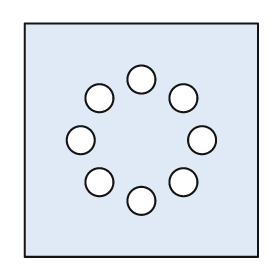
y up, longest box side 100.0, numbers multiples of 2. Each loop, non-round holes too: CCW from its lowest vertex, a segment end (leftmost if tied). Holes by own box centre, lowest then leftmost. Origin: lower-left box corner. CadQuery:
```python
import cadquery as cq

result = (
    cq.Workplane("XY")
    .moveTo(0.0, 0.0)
    .lineTo(100.0, 0.0)
    .lineTo(100.0, 100.0)
    .lineTo(0.0, 100.0)
    .close()
    .moveTo(50.0, 24.0)
    .circle(6.0)
    .moveTo(32.0, 32.0)
    .circle(6.0)
    .moveTo(68.0, 32.0)
    .circle(6.0)
    .moveTo(24.0, 50.0)
    .circle(6.0)
    .moveTo(76.0, 50.0)
    .circle(6.0)
    .moveTo(32.0, 68.0)
    .circle(6.0)
    .moveTo(68.0, 68.0)
    .circle(6.0)
    .moveTo(50.0, 76.0)
    .circle(6.0)
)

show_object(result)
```